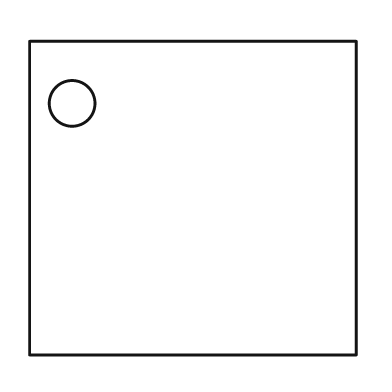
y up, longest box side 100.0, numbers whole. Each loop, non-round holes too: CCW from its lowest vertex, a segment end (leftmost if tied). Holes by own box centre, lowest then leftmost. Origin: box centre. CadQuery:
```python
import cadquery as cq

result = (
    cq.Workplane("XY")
    .moveTo(-50.0, -48.0)
    .lineTo(50.0, -48.0)
    .lineTo(50.0, 48.0)
    .lineTo(-50.0, 48.0)
    .close()
    .moveTo(-37.0, 29.0)
    .circle(7.0)
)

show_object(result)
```